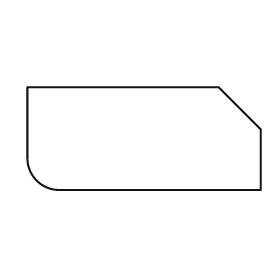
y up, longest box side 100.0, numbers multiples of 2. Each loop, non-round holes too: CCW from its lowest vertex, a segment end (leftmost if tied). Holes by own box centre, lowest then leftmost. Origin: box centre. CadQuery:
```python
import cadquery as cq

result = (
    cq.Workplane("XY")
    .moveTo(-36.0, -22.0)
    .lineTo(50.0, -22.0)
    .lineTo(50.0, 4.0)
    .lineTo(32.0, 22.0)
    .lineTo(-50.0, 22.0)
    .lineTo(-50.0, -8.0)
    .threePointArc((-46.0, -18.0), (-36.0, -22.0))
    .close()
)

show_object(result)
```